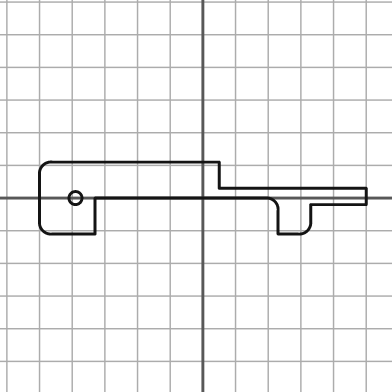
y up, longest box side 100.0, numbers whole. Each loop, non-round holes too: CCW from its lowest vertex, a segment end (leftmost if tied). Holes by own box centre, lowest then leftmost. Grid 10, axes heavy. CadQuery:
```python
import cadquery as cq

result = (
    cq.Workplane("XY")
    .moveTo(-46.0, -11.0)
    .lineTo(-33.0, -11.0)
    .lineTo(-33.0, 0.0)
    .lineTo(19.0, 0.0)
    .threePointArc((22.0, -1.0), (23.0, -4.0))
    .lineTo(23.0, -11.0)
    .lineTo(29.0, -11.0)
    .threePointArc((32.0, -10.0), (33.0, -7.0))
    .lineTo(33.0, -2.0)
    .lineTo(50.0, -2.0)
    .lineTo(50.0, 3.0)
    .lineTo(5.0, 3.0)
    .lineTo(5.0, 11.0)
    .lineTo(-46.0, 11.0)
    .threePointArc((-49.0, 10.0), (-50.0, 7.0))
    .lineTo(-50.0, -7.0)
    .threePointArc((-49.0, -10.0), (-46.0, -11.0))
    .close()
    .moveTo(-39.0, 0.0)
    .circle(2.0)
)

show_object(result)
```